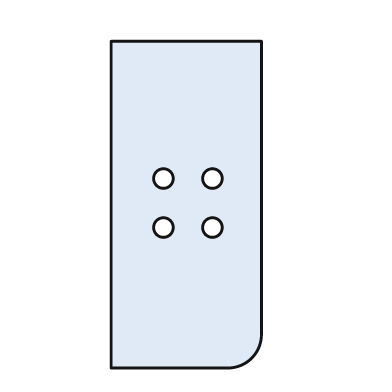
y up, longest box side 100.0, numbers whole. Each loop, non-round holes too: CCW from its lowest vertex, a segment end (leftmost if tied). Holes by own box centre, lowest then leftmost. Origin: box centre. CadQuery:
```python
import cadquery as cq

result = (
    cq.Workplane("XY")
    .moveTo(-23.0, -50.0)
    .lineTo(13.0, -50.0)
    .threePointArc((20.0, -47.0), (23.0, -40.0))
    .lineTo(23.0, 50.0)
    .lineTo(-23.0, 50.0)
    .close()
    .moveTo(-7.0, -7.0)
    .circle(3.0)
    .moveTo(8.0, -7.0)
    .circle(3.0)
    .moveTo(-7.0, 8.0)
    .circle(3.0)
    .moveTo(8.0, 8.0)
    .circle(3.0)
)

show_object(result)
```